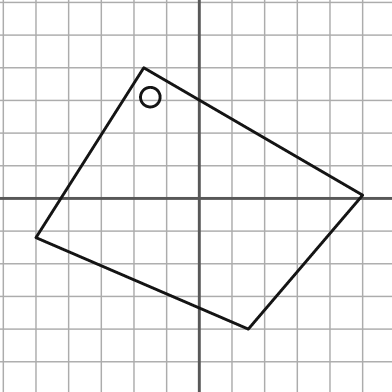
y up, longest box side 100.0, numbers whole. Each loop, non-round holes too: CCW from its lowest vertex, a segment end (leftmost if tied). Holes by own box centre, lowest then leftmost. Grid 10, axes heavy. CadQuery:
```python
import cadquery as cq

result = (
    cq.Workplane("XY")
    .moveTo(15.0, -40.0)
    .lineTo(50.0, 1.0)
    .lineTo(-17.0, 40.0)
    .lineTo(-50.0, -12.0)
    .close()
    .moveTo(-15.0, 31.0)
    .circle(3.0)
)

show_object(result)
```